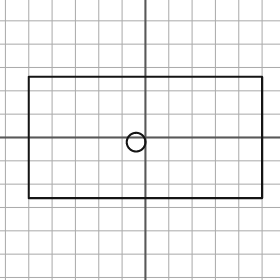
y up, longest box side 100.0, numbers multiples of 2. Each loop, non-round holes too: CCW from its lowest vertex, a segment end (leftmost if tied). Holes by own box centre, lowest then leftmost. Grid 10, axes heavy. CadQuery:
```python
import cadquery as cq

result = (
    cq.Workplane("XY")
    .moveTo(-50.0, -26.0)
    .lineTo(50.0, -26.0)
    .lineTo(50.0, 26.0)
    .lineTo(-50.0, 26.0)
    .close()
    .moveTo(-4.0, -2.0)
    .circle(4.0)
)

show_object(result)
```